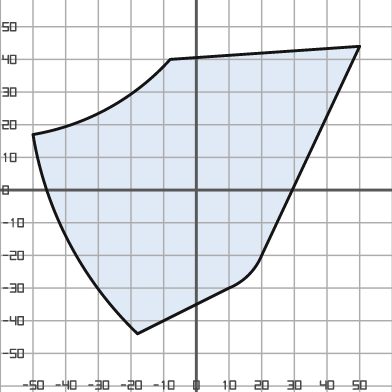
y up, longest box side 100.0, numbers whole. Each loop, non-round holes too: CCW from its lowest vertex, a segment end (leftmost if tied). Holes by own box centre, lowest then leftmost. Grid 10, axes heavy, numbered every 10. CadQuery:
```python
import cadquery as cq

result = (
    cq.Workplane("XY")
    .moveTo(-18.0, -44.0)
    .lineTo(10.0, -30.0)
    .threePointArc((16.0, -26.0), (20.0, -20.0))
    .lineTo(50.0, 44.0)
    .lineTo(-8.0, 40.0)
    .threePointArc((-27.0, 25.0), (-50.0, 17.0))
    .threePointArc((-39.0, -16.0), (-18.0, -44.0))
    .close()
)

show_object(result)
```